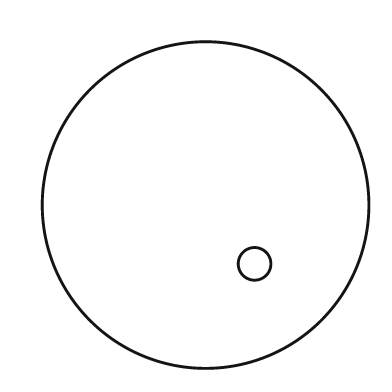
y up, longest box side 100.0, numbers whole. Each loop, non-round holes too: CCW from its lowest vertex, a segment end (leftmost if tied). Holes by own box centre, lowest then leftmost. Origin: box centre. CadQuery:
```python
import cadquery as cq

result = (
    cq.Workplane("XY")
    .moveTo(0.0, 0.0)
    .circle(50.0)
    .moveTo(15.0, -18.0)
    .circle(5.0)
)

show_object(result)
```